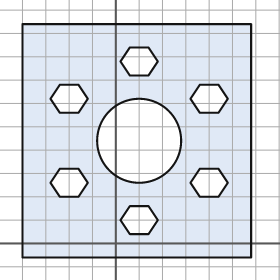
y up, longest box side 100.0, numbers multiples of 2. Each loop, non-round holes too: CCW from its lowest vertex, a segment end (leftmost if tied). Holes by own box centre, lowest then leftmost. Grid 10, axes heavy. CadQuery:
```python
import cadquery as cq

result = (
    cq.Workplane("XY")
    .moveTo(-40.0, -6.0)
    .lineTo(58.0, -6.0)
    .lineTo(58.0, 94.0)
    .lineTo(-40.0, 94.0)
    .close()
    .moveTo(6.0, 4.0)
    .lineTo(14.0, 4.0)
    .lineTo(18.0, 10.0)
    .lineTo(14.0, 16.0)
    .lineTo(6.0, 16.0)
    .lineTo(2.0, 10.0)
    .close()
    .moveTo(-24.0, 20.0)
    .lineTo(-16.0, 20.0)
    .lineTo(-12.0, 26.0)
    .lineTo(-16.0, 32.0)
    .lineTo(-24.0, 32.0)
    .lineTo(-28.0, 26.0)
    .close()
    .moveTo(36.0, 20.0)
    .lineTo(44.0, 20.0)
    .lineTo(48.0, 26.0)
    .lineTo(44.0, 32.0)
    .lineTo(36.0, 32.0)
    .lineTo(32.0, 26.0)
    .close()
    .moveTo(10.0, 44.0)
    .circle(18.0)
    .moveTo(-24.0, 56.0)
    .lineTo(-16.0, 56.0)
    .lineTo(-12.0, 62.0)
    .lineTo(-16.0, 68.0)
    .lineTo(-24.0, 68.0)
    .lineTo(-28.0, 62.0)
    .close()
    .moveTo(36.0, 56.0)
    .lineTo(44.0, 56.0)
    .lineTo(48.0, 62.0)
    .lineTo(44.0, 68.0)
    .lineTo(36.0, 68.0)
    .lineTo(32.0, 62.0)
    .close()
    .moveTo(6.0, 72.0)
    .lineTo(14.0, 72.0)
    .lineTo(18.0, 78.0)
    .lineTo(14.0, 84.0)
    .lineTo(6.0, 84.0)
    .lineTo(2.0, 78.0)
    .close()
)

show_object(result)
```